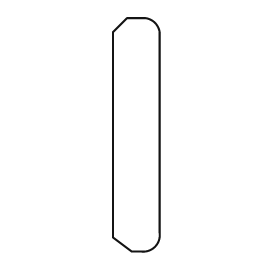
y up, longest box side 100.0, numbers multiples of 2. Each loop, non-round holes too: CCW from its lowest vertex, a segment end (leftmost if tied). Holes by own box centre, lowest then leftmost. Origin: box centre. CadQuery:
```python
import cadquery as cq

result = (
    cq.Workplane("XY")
    .moveTo(-2.0, -50.0)
    .lineTo(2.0, -50.0)
    .threePointArc((8.0, -48.0), (10.0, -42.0))
    .lineTo(10.0, 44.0)
    .threePointArc((8.0, 48.0), (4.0, 50.0))
    .lineTo(-4.0, 50.0)
    .lineTo(-10.0, 44.0)
    .lineTo(-10.0, -44.0)
    .close()
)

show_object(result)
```